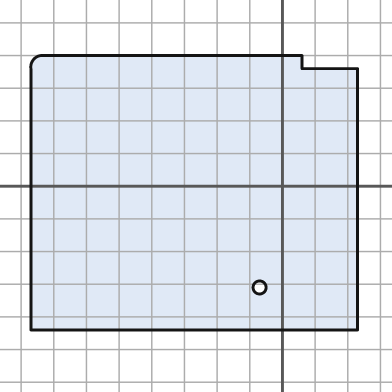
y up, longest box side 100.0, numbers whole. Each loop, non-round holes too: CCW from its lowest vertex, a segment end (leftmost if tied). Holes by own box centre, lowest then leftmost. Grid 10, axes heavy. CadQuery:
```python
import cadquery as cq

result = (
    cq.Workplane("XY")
    .moveTo(-77.0, -44.0)
    .lineTo(23.0, -44.0)
    .lineTo(23.0, 36.0)
    .lineTo(6.0, 36.0)
    .lineTo(6.0, 40.0)
    .lineTo(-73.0, 40.0)
    .threePointArc((-76.0, 39.0), (-77.0, 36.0))
    .close()
    .moveTo(-7.0, -31.0)
    .circle(2.0)
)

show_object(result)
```